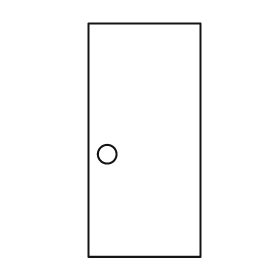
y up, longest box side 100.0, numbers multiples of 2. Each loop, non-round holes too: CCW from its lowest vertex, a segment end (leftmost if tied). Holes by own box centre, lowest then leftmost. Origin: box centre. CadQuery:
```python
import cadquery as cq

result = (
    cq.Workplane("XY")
    .moveTo(-24.0, -50.0)
    .lineTo(24.0, -50.0)
    .lineTo(24.0, 50.0)
    .lineTo(-24.0, 50.0)
    .close()
    .moveTo(-16.0, -6.0)
    .circle(4.0)
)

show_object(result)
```